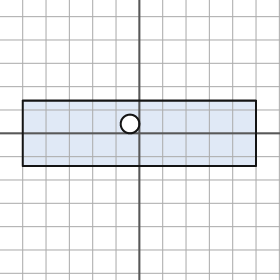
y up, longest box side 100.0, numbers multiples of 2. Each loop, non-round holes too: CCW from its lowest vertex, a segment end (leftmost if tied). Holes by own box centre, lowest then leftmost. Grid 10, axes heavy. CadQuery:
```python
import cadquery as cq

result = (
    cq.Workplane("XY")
    .moveTo(-50.0, -14.0)
    .lineTo(50.0, -14.0)
    .lineTo(50.0, 14.0)
    .lineTo(-50.0, 14.0)
    .close()
    .moveTo(-4.0, 4.0)
    .circle(4.0)
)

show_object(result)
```